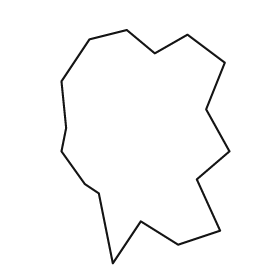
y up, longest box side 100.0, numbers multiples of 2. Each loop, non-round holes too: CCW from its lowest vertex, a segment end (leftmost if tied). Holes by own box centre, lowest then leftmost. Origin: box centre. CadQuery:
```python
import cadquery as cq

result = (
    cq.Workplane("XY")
    .moveTo(-14.0, -50.0)
    .lineTo(-2.0, -32.0)
    .lineTo(14.0, -42.0)
    .lineTo(32.0, -36.0)
    .lineTo(22.0, -14.0)
    .lineTo(36.0, -2.0)
    .lineTo(26.0, 16.0)
    .lineTo(34.0, 36.0)
    .lineTo(18.0, 48.0)
    .lineTo(4.0, 40.0)
    .lineTo(-8.0, 50.0)
    .lineTo(-24.0, 46.0)
    .lineTo(-36.0, 28.0)
    .lineTo(-34.0, 8.0)
    .lineTo(-36.0, -2.0)
    .lineTo(-26.0, -16.0)
    .lineTo(-20.0, -20.0)
    .close()
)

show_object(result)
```